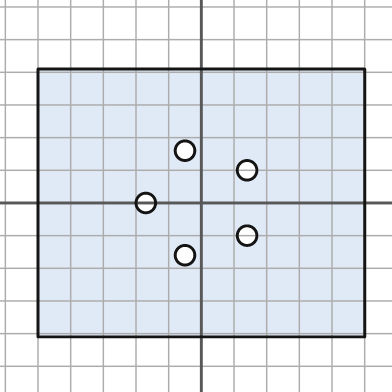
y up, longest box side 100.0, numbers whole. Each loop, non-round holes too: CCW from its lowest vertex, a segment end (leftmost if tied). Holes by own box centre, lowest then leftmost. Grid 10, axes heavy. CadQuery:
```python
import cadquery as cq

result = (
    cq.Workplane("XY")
    .moveTo(-50.0, -41.0)
    .lineTo(50.0, -41.0)
    .lineTo(50.0, 41.0)
    .lineTo(-50.0, 41.0)
    .close()
    .moveTo(-5.0, -16.0)
    .circle(3.0)
    .moveTo(14.0, -10.0)
    .circle(3.0)
    .moveTo(-17.0, 0.0)
    .circle(3.0)
    .moveTo(14.0, 10.0)
    .circle(3.0)
    .moveTo(-5.0, 16.0)
    .circle(3.0)
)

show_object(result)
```